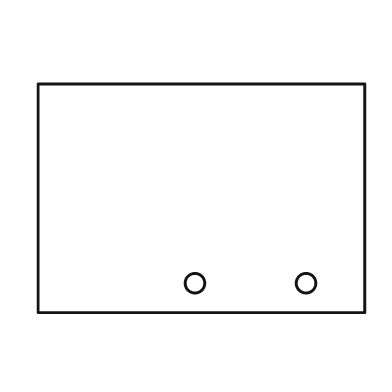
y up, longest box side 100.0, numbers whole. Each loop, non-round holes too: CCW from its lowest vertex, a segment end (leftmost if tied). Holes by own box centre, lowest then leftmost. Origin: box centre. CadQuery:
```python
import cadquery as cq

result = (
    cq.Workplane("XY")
    .moveTo(-50.0, -35.0)
    .lineTo(50.0, -35.0)
    .lineTo(50.0, 35.0)
    .lineTo(-50.0, 35.0)
    .close()
    .moveTo(-2.0, -26.0)
    .circle(3.0)
    .moveTo(32.0, -26.0)
    .circle(3.0)
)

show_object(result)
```